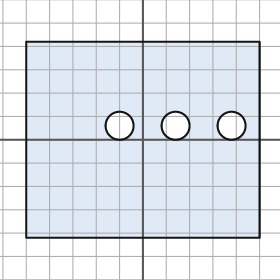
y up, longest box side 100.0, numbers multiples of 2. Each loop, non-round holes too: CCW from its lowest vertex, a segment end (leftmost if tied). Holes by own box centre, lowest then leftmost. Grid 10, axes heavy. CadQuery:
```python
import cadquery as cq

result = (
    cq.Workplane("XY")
    .moveTo(-50.0, -42.0)
    .lineTo(50.0, -42.0)
    .lineTo(50.0, 42.0)
    .lineTo(-50.0, 42.0)
    .close()
    .moveTo(-10.0, 6.0)
    .circle(6.0)
    .moveTo(14.0, 6.0)
    .circle(6.0)
    .moveTo(38.0, 6.0)
    .circle(6.0)
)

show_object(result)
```